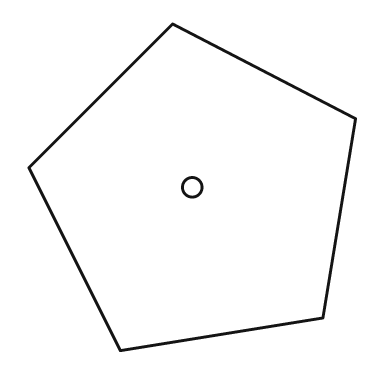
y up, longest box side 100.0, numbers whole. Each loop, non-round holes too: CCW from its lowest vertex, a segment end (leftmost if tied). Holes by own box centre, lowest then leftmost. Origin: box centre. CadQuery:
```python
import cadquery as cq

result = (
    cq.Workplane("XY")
    .moveTo(-22.0, -50.0)
    .lineTo(40.0, -40.0)
    .lineTo(50.0, 21.0)
    .lineTo(-6.0, 50.0)
    .lineTo(-50.0, 6.0)
    .close()
    .moveTo(0.0, 0.0)
    .circle(3.0)
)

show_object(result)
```